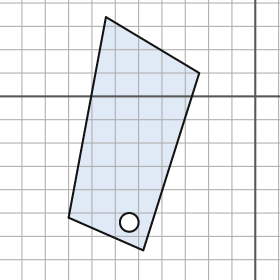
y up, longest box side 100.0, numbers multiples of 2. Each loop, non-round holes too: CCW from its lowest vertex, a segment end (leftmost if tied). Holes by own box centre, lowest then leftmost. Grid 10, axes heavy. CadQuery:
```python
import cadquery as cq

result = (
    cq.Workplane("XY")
    .moveTo(-48.0, -66.0)
    .lineTo(-24.0, 10.0)
    .lineTo(-64.0, 34.0)
    .lineTo(-80.0, -52.0)
    .close()
    .moveTo(-54.0, -54.0)
    .circle(4.0)
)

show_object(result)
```